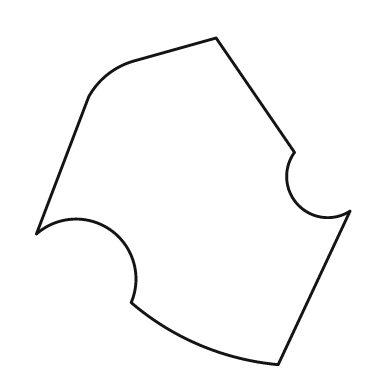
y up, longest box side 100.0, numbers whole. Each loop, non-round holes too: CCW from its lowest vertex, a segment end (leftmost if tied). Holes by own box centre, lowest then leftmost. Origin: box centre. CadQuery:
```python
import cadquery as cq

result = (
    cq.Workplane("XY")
    .moveTo(26.0, -50.0)
    .lineTo(48.0, -3.0)
    .threePointArc((32.0, -1.0), (31.0, 15.0))
    .lineTo(7.0, 50.0)
    .lineTo(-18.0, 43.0)
    .threePointArc((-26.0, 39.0), (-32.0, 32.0))
    .lineTo(-48.0, -10.0)
    .threePointArc((-25.0, -9.0), (-19.0, -31.0))
    .threePointArc((2.0, -44.0), (26.0, -50.0))
    .close()
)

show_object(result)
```